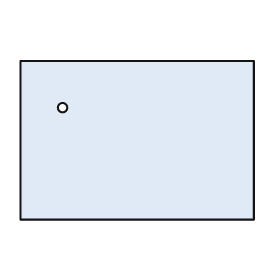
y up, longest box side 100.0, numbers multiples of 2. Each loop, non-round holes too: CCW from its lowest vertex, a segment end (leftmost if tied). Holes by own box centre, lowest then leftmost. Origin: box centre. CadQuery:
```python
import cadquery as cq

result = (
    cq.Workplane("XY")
    .moveTo(-50.0, -34.0)
    .lineTo(50.0, -34.0)
    .lineTo(50.0, 34.0)
    .lineTo(-50.0, 34.0)
    .close()
    .moveTo(-32.0, 14.0)
    .circle(2.0)
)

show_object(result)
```